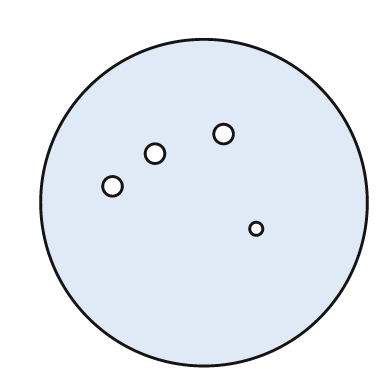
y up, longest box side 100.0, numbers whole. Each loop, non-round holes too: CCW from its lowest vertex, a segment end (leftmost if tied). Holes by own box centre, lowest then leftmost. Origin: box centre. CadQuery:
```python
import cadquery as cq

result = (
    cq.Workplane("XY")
    .moveTo(0.0, 0.0)
    .circle(50.0)
    .moveTo(16.0, -8.0)
    .circle(2.0)
    .moveTo(-28.0, 5.0)
    .circle(3.0)
    .moveTo(-15.0, 15.0)
    .circle(3.0)
    .moveTo(6.0, 21.0)
    .circle(3.0)
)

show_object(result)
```